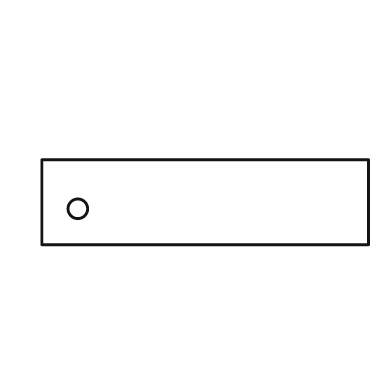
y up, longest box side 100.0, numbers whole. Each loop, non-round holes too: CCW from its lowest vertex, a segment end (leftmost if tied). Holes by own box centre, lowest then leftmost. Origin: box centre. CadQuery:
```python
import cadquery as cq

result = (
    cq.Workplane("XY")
    .moveTo(-50.0, -13.0)
    .lineTo(50.0, -13.0)
    .lineTo(50.0, 13.0)
    .lineTo(-50.0, 13.0)
    .close()
    .moveTo(-39.0, -2.0)
    .circle(3.0)
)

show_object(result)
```